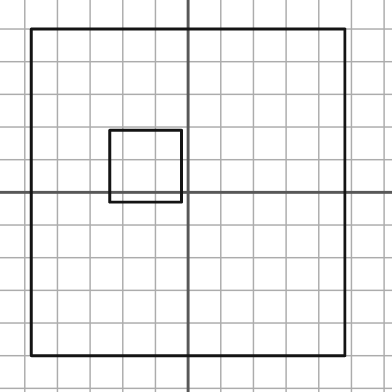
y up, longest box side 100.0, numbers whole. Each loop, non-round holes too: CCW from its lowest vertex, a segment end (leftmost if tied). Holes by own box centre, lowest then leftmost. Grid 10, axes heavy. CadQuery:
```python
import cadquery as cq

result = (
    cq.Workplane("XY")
    .moveTo(-48.0, -50.0)
    .lineTo(48.0, -50.0)
    .lineTo(48.0, 50.0)
    .lineTo(-48.0, 50.0)
    .close()
    .moveTo(-24.0, -3.0)
    .lineTo(-2.0, -3.0)
    .lineTo(-2.0, 19.0)
    .lineTo(-24.0, 19.0)
    .close()
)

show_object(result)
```